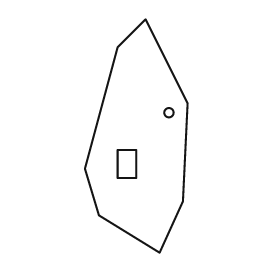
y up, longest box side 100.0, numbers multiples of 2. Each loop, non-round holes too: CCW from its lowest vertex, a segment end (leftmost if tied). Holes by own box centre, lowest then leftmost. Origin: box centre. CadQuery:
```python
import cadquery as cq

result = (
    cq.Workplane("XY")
    .moveTo(10.0, -50.0)
    .lineTo(20.0, -28.0)
    .lineTo(22.0, 14.0)
    .lineTo(4.0, 50.0)
    .lineTo(-8.0, 38.0)
    .lineTo(-22.0, -14.0)
    .lineTo(-16.0, -34.0)
    .close()
    .moveTo(-8.0, -18.0)
    .lineTo(0.0, -18.0)
    .lineTo(0.0, -6.0)
    .lineTo(-8.0, -6.0)
    .close()
    .moveTo(14.0, 10.0)
    .circle(2.0)
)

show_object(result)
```